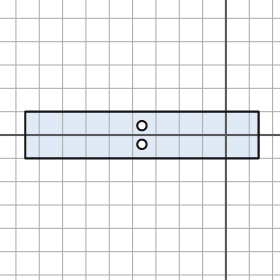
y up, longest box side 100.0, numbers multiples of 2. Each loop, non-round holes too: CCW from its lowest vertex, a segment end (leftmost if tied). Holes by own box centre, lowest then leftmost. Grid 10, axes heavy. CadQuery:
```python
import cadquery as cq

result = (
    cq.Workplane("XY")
    .moveTo(-86.0, -10.0)
    .lineTo(14.0, -10.0)
    .lineTo(14.0, 10.0)
    .lineTo(-86.0, 10.0)
    .close()
    .moveTo(-36.0, -4.0)
    .circle(2.0)
    .moveTo(-36.0, 4.0)
    .circle(2.0)
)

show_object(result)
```